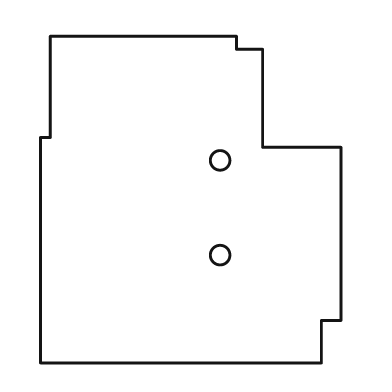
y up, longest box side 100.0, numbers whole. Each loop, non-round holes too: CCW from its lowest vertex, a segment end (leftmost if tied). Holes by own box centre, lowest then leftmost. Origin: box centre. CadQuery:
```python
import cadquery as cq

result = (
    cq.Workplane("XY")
    .moveTo(-46.0, -50.0)
    .lineTo(40.0, -50.0)
    .lineTo(40.0, -37.0)
    .lineTo(46.0, -37.0)
    .lineTo(46.0, 16.0)
    .lineTo(22.0, 16.0)
    .lineTo(22.0, 46.0)
    .lineTo(14.0, 46.0)
    .lineTo(14.0, 50.0)
    .lineTo(-43.0, 50.0)
    .lineTo(-43.0, 19.0)
    .lineTo(-46.0, 19.0)
    .close()
    .moveTo(9.0, -17.0)
    .circle(3.0)
    .moveTo(9.0, 12.0)
    .circle(3.0)
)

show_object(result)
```